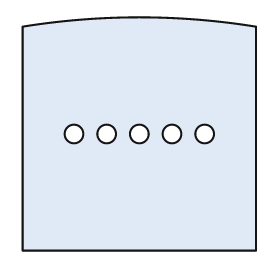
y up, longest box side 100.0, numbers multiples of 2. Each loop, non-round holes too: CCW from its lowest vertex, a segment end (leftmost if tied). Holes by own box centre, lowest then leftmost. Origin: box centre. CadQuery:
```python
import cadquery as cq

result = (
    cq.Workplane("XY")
    .moveTo(-50.0, -50.0)
    .lineTo(50.0, -50.0)
    .lineTo(50.0, 46.0)
    .threePointArc((0.0, 50.0), (-50.0, 46.0))
    .close()
    .moveTo(-28.0, 0.0)
    .circle(4.0)
    .moveTo(-14.0, 0.0)
    .circle(4.0)
    .moveTo(0.0, 0.0)
    .circle(4.0)
    .moveTo(14.0, 0.0)
    .circle(4.0)
    .moveTo(28.0, 0.0)
    .circle(4.0)
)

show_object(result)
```